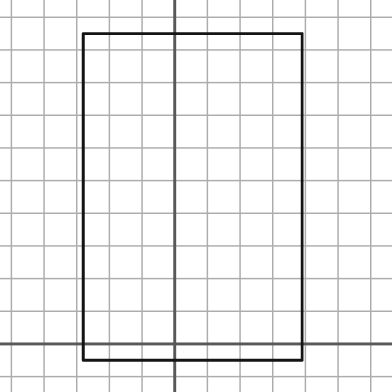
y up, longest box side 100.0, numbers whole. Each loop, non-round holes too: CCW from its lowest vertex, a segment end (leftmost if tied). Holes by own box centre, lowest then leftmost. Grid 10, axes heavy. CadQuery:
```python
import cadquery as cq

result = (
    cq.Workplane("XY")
    .moveTo(-28.0, -5.0)
    .lineTo(39.0, -5.0)
    .lineTo(39.0, 95.0)
    .lineTo(-28.0, 95.0)
    .close()
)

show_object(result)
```